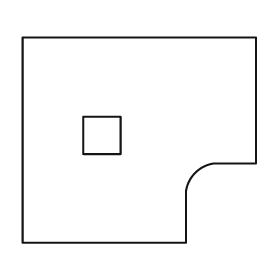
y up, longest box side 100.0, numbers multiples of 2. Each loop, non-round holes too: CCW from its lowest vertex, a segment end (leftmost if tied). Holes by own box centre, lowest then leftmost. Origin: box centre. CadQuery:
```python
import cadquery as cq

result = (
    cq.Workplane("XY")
    .moveTo(-50.0, -44.0)
    .lineTo(20.0, -44.0)
    .lineTo(20.0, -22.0)
    .threePointArc((24.0, -14.0), (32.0, -10.0))
    .lineTo(50.0, -10.0)
    .lineTo(50.0, 44.0)
    .lineTo(-50.0, 44.0)
    .close()
    .moveTo(-24.0, -6.0)
    .lineTo(-8.0, -6.0)
    .lineTo(-8.0, 10.0)
    .lineTo(-24.0, 10.0)
    .close()
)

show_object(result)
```